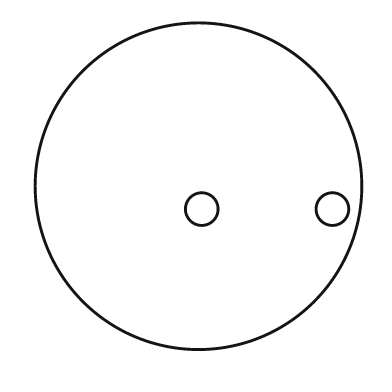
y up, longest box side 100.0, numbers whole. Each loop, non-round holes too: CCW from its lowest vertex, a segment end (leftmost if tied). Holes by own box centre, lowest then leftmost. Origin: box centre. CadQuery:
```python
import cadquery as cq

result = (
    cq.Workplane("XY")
    .moveTo(0.0, 0.0)
    .circle(50.0)
    .moveTo(1.0, -7.0)
    .circle(5.0)
    .moveTo(41.0, -7.0)
    .circle(5.0)
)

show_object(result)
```